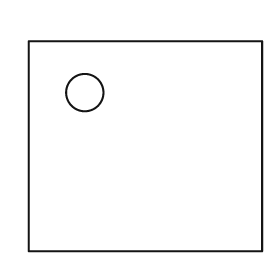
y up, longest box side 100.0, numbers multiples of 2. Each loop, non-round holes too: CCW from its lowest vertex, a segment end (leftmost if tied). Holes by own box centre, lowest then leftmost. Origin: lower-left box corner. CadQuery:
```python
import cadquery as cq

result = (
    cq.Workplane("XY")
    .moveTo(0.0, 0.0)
    .lineTo(100.0, 0.0)
    .lineTo(100.0, 90.0)
    .lineTo(0.0, 90.0)
    .close()
    .moveTo(24.0, 68.0)
    .circle(8.0)
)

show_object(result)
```